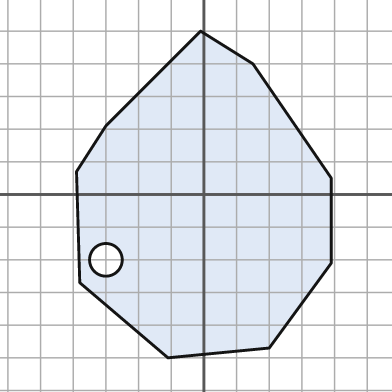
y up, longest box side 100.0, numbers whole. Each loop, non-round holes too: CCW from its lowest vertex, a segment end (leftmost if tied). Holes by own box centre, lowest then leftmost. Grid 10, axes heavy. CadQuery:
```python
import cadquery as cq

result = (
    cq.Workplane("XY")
    .moveTo(-11.0, -50.0)
    .lineTo(20.0, -47.0)
    .lineTo(39.0, -21.0)
    .lineTo(39.0, 5.0)
    .lineTo(15.0, 40.0)
    .lineTo(-1.0, 50.0)
    .lineTo(-30.0, 21.0)
    .lineTo(-39.0, 7.0)
    .lineTo(-38.0, -27.0)
    .close()
    .moveTo(-30.0, -20.0)
    .circle(5.0)
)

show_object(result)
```